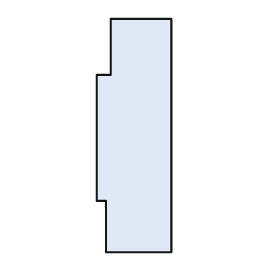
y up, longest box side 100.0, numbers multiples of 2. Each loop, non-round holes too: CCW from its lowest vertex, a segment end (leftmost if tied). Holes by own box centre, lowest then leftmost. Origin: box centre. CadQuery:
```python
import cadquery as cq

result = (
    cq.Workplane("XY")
    .moveTo(-12.0, -50.0)
    .lineTo(16.0, -50.0)
    .lineTo(16.0, 50.0)
    .lineTo(-10.0, 50.0)
    .lineTo(-10.0, 26.0)
    .lineTo(-16.0, 26.0)
    .lineTo(-16.0, -28.0)
    .lineTo(-12.0, -28.0)
    .close()
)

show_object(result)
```